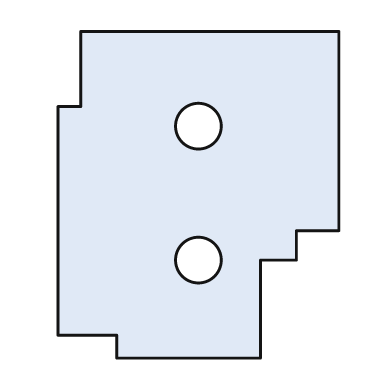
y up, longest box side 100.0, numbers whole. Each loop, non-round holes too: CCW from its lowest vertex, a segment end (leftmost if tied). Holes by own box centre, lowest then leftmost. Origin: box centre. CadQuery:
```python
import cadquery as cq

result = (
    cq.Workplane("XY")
    .moveTo(-25.0, -50.0)
    .lineTo(19.0, -50.0)
    .lineTo(19.0, -20.0)
    .lineTo(30.0, -20.0)
    .lineTo(30.0, -11.0)
    .lineTo(43.0, -11.0)
    .lineTo(43.0, 50.0)
    .lineTo(-36.0, 50.0)
    .lineTo(-36.0, 27.0)
    .lineTo(-43.0, 27.0)
    .lineTo(-43.0, -43.0)
    .lineTo(-25.0, -43.0)
    .close()
    .moveTo(0.0, -20.0)
    .circle(7.0)
    .moveTo(0.0, 21.0)
    .circle(7.0)
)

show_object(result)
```